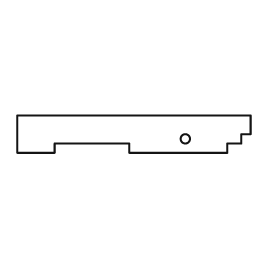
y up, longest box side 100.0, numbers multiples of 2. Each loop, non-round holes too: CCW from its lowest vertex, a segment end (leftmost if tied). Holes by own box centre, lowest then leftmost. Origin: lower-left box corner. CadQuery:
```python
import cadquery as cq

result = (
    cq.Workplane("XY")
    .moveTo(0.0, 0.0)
    .lineTo(16.0, 0.0)
    .lineTo(16.0, 4.0)
    .lineTo(48.0, 4.0)
    .lineTo(48.0, 0.0)
    .lineTo(90.0, 0.0)
    .lineTo(90.0, 4.0)
    .lineTo(96.0, 4.0)
    .lineTo(96.0, 8.0)
    .lineTo(100.0, 8.0)
    .lineTo(100.0, 16.0)
    .lineTo(0.0, 16.0)
    .close()
    .moveTo(72.0, 6.0)
    .circle(2.0)
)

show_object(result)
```